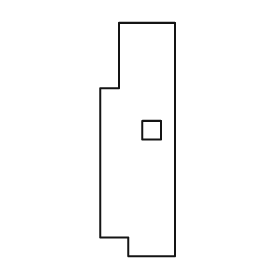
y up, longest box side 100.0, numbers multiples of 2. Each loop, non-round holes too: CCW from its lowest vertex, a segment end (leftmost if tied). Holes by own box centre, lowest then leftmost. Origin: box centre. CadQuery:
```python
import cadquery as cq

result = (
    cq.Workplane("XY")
    .moveTo(-4.0, -50.0)
    .lineTo(16.0, -50.0)
    .lineTo(16.0, 50.0)
    .lineTo(-8.0, 50.0)
    .lineTo(-8.0, 22.0)
    .lineTo(-16.0, 22.0)
    .lineTo(-16.0, -42.0)
    .lineTo(-4.0, -42.0)
    .close()
    .moveTo(2.0, 0.0)
    .lineTo(10.0, 0.0)
    .lineTo(10.0, 8.0)
    .lineTo(2.0, 8.0)
    .close()
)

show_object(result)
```